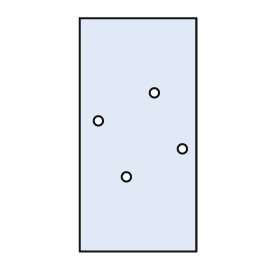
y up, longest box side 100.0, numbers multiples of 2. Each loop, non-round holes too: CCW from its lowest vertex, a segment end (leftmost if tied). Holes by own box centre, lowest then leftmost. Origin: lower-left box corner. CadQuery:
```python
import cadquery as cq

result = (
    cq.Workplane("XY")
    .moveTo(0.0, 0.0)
    .lineTo(50.0, 0.0)
    .lineTo(50.0, 100.0)
    .lineTo(0.0, 100.0)
    .close()
    .moveTo(20.0, 32.0)
    .circle(2.0)
    .moveTo(44.0, 44.0)
    .circle(2.0)
    .moveTo(8.0, 56.0)
    .circle(2.0)
    .moveTo(32.0, 68.0)
    .circle(2.0)
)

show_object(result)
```